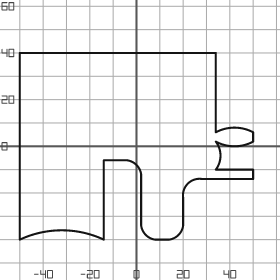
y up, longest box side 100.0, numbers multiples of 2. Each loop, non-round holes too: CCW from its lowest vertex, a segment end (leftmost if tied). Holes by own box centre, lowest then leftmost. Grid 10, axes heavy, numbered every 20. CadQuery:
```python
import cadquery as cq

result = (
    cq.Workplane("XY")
    .moveTo(-50.0, -40.0)
    .threePointArc((-32.0, -36.0), (-14.0, -40.0))
    .lineTo(-14.0, -6.0)
    .lineTo(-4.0, -6.0)
    .threePointArc((0.0, -8.0), (2.0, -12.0))
    .lineTo(2.0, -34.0)
    .threePointArc((4.0, -38.0), (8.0, -40.0))
    .lineTo(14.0, -40.0)
    .threePointArc((18.0, -38.0), (20.0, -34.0))
    .lineTo(20.0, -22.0)
    .threePointArc((22.0, -16.0), (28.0, -14.0))
    .lineTo(50.0, -14.0)
    .lineTo(50.0, -10.0)
    .lineTo(34.0, -10.0)
    .threePointArc((36.0, -4.0), (34.0, 2.0))
    .threePointArc((42.0, 0.0), (50.0, 2.0))
    .lineTo(50.0, 6.0)
    .threePointArc((42.0, 8.0), (34.0, 6.0))
    .lineTo(34.0, 40.0)
    .lineTo(-50.0, 40.0)
    .close()
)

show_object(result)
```